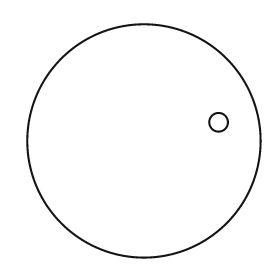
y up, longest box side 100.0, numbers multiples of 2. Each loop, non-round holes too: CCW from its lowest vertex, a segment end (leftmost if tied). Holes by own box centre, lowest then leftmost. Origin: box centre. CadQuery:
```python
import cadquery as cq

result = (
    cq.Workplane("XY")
    .moveTo(0.0, 0.0)
    .circle(50.0)
    .moveTo(32.0, 8.0)
    .circle(4.0)
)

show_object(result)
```